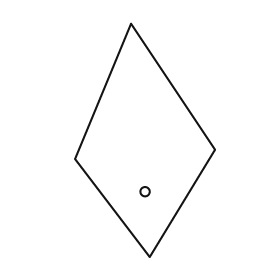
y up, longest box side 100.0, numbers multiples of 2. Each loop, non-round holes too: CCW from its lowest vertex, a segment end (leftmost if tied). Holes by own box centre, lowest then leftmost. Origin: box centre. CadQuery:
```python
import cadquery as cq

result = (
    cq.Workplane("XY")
    .moveTo(2.0, -50.0)
    .lineTo(30.0, -4.0)
    .lineTo(-6.0, 50.0)
    .lineTo(-30.0, -8.0)
    .close()
    .moveTo(0.0, -22.0)
    .circle(2.0)
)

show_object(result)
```